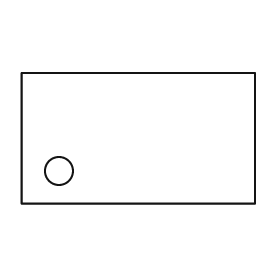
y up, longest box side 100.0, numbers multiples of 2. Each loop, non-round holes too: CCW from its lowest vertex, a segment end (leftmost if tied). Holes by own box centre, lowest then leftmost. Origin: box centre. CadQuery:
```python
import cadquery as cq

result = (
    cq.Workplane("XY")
    .moveTo(-50.0, -28.0)
    .lineTo(50.0, -28.0)
    .lineTo(50.0, 28.0)
    .lineTo(-50.0, 28.0)
    .close()
    .moveTo(-34.0, -14.0)
    .circle(6.0)
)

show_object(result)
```